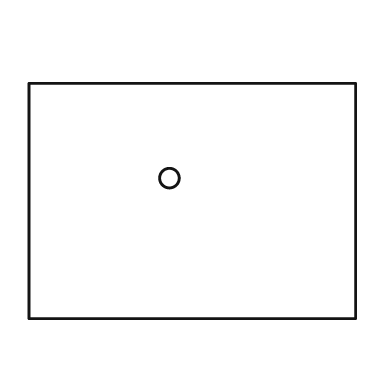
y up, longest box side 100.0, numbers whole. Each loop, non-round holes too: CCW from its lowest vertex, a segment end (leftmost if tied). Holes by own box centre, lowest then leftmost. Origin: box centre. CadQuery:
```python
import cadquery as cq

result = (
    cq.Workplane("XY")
    .moveTo(-50.0, -36.0)
    .lineTo(50.0, -36.0)
    .lineTo(50.0, 36.0)
    .lineTo(-50.0, 36.0)
    .close()
    .moveTo(-7.0, 7.0)
    .circle(3.0)
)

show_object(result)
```